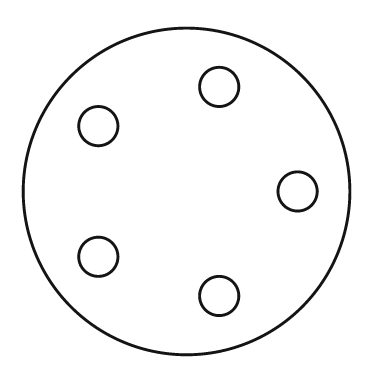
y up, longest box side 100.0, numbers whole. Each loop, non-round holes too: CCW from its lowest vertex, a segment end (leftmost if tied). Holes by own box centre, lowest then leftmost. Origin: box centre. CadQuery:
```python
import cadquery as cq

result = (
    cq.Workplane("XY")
    .moveTo(0.0, 0.0)
    .circle(50.0)
    .moveTo(10.0, -32.0)
    .circle(6.0)
    .moveTo(-27.0, -20.0)
    .circle(6.0)
    .moveTo(34.0, 0.0)
    .circle(6.0)
    .moveTo(-27.0, 20.0)
    .circle(6.0)
    .moveTo(10.0, 32.0)
    .circle(6.0)
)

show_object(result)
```